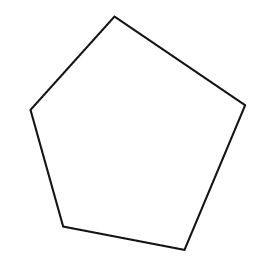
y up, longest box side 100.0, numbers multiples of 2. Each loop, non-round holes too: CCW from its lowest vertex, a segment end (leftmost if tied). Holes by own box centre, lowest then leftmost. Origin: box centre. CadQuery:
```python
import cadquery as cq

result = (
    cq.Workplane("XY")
    .moveTo(20.0, -50.0)
    .lineTo(46.0, 12.0)
    .lineTo(-10.0, 50.0)
    .lineTo(-46.0, 10.0)
    .lineTo(-32.0, -40.0)
    .close()
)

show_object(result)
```